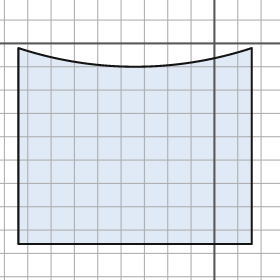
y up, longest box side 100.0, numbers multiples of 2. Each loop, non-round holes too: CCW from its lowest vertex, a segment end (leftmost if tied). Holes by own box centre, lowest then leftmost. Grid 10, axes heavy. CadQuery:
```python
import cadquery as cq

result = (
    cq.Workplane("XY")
    .moveTo(-84.0, -86.0)
    .lineTo(16.0, -86.0)
    .lineTo(16.0, -2.0)
    .threePointArc((-34.0, -10.0), (-84.0, -2.0))
    .close()
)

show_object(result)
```